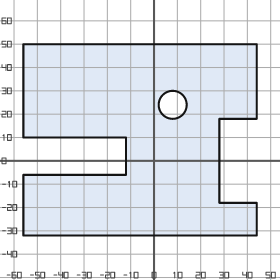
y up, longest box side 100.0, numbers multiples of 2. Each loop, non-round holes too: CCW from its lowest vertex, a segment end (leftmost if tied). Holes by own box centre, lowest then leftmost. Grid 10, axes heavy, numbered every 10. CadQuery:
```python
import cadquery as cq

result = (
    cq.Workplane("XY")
    .moveTo(-56.0, -32.0)
    .lineTo(44.0, -32.0)
    .lineTo(44.0, -18.0)
    .lineTo(28.0, -18.0)
    .lineTo(28.0, 18.0)
    .lineTo(44.0, 18.0)
    .lineTo(44.0, 50.0)
    .lineTo(-56.0, 50.0)
    .lineTo(-56.0, 10.0)
    .lineTo(-12.0, 10.0)
    .lineTo(-12.0, -6.0)
    .lineTo(-56.0, -6.0)
    .close()
    .moveTo(8.0, 24.0)
    .circle(6.0)
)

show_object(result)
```